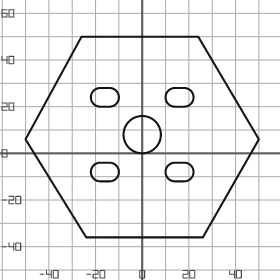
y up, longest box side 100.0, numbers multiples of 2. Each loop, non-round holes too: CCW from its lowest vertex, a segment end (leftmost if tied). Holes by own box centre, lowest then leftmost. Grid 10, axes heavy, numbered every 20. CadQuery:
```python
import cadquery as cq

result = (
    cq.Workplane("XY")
    .moveTo(-24.0, -36.0)
    .lineTo(26.0, -36.0)
    .lineTo(50.0, 6.0)
    .lineTo(24.0, 50.0)
    .lineTo(-26.0, 50.0)
    .lineTo(-50.0, 6.0)
    .close()
    .moveTo(-18.0, -12.0)
    .lineTo(-14.0, -12.0)
    .threePointArc((-10.0, -8.0), (-14.0, -4.0))
    .lineTo(-18.0, -4.0)
    .threePointArc((-22.0, -8.0), (-18.0, -12.0))
    .close()
    .moveTo(14.0, -12.0)
    .lineTo(18.0, -12.0)
    .threePointArc((22.0, -8.0), (18.0, -4.0))
    .lineTo(14.0, -4.0)
    .threePointArc((10.0, -8.0), (14.0, -12.0))
    .close()
    .moveTo(0.0, 8.0)
    .circle(8.0)
    .moveTo(-18.0, 20.0)
    .lineTo(-14.0, 20.0)
    .threePointArc((-10.0, 24.0), (-14.0, 28.0))
    .lineTo(-18.0, 28.0)
    .threePointArc((-22.0, 24.0), (-18.0, 20.0))
    .close()
    .moveTo(14.0, 20.0)
    .lineTo(18.0, 20.0)
    .threePointArc((22.0, 24.0), (18.0, 28.0))
    .lineTo(14.0, 28.0)
    .threePointArc((10.0, 24.0), (14.0, 20.0))
    .close()
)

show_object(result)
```